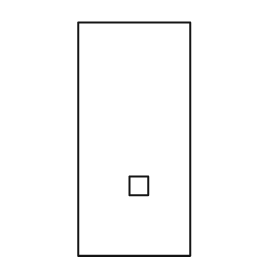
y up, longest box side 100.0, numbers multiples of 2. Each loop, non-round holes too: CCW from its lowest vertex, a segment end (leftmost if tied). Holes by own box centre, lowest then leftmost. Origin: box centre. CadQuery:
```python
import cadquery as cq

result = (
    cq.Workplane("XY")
    .moveTo(-24.0, -50.0)
    .lineTo(24.0, -50.0)
    .lineTo(24.0, 50.0)
    .lineTo(-24.0, 50.0)
    .close()
    .moveTo(-2.0, -24.0)
    .lineTo(6.0, -24.0)
    .lineTo(6.0, -16.0)
    .lineTo(-2.0, -16.0)
    .close()
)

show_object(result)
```